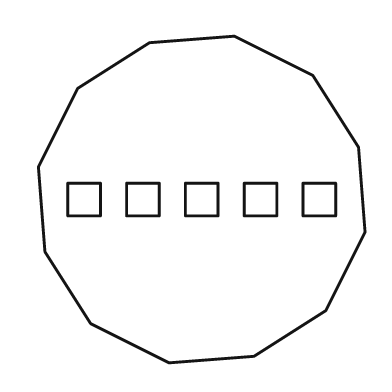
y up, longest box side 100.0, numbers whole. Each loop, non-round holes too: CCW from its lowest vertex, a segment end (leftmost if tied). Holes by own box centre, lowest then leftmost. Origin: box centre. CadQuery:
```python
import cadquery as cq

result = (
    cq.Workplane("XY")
    .moveTo(-10.0, -50.0)
    .lineTo(16.0, -48.0)
    .lineTo(38.0, -34.0)
    .lineTo(50.0, -10.0)
    .lineTo(48.0, 16.0)
    .lineTo(34.0, 38.0)
    .lineTo(10.0, 50.0)
    .lineTo(-16.0, 48.0)
    .lineTo(-38.0, 34.0)
    .lineTo(-50.0, 10.0)
    .lineTo(-48.0, -16.0)
    .lineTo(-34.0, -38.0)
    .close()
    .moveTo(-41.0, -5.0)
    .lineTo(-31.0, -5.0)
    .lineTo(-31.0, 5.0)
    .lineTo(-41.0, 5.0)
    .close()
    .moveTo(-23.0, -5.0)
    .lineTo(-13.0, -5.0)
    .lineTo(-13.0, 5.0)
    .lineTo(-23.0, 5.0)
    .close()
    .moveTo(-5.0, -5.0)
    .lineTo(5.0, -5.0)
    .lineTo(5.0, 5.0)
    .lineTo(-5.0, 5.0)
    .close()
    .moveTo(13.0, -5.0)
    .lineTo(23.0, -5.0)
    .lineTo(23.0, 5.0)
    .lineTo(13.0, 5.0)
    .close()
    .moveTo(31.0, -5.0)
    .lineTo(41.0, -5.0)
    .lineTo(41.0, 5.0)
    .lineTo(31.0, 5.0)
    .close()
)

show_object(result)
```